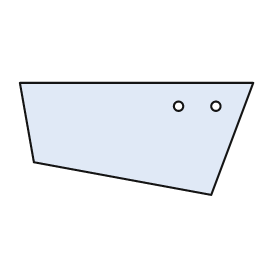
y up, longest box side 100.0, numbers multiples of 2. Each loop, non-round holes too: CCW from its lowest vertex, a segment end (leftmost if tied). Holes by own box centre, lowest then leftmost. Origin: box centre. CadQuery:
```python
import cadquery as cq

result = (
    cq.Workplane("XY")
    .moveTo(32.0, -24.0)
    .lineTo(50.0, 24.0)
    .lineTo(-50.0, 24.0)
    .lineTo(-44.0, -10.0)
    .close()
    .moveTo(18.0, 14.0)
    .circle(2.0)
    .moveTo(34.0, 14.0)
    .circle(2.0)
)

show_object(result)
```